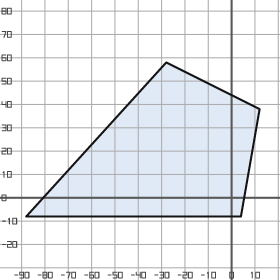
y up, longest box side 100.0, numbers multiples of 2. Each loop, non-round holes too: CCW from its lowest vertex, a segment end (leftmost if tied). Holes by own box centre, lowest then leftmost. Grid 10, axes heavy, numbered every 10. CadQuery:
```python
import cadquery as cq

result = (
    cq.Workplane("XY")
    .moveTo(-88.0, -8.0)
    .lineTo(4.0, -8.0)
    .lineTo(12.0, 38.0)
    .lineTo(-28.0, 58.0)
    .close()
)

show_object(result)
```